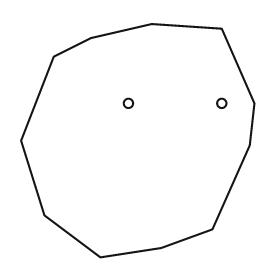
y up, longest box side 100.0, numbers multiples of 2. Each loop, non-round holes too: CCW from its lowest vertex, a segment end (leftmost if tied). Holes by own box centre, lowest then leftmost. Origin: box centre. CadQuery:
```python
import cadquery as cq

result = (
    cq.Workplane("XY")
    .moveTo(-16.0, -50.0)
    .lineTo(10.0, -46.0)
    .lineTo(32.0, -38.0)
    .lineTo(48.0, -2.0)
    .lineTo(50.0, 16.0)
    .lineTo(36.0, 48.0)
    .lineTo(6.0, 50.0)
    .lineTo(-20.0, 44.0)
    .lineTo(-36.0, 36.0)
    .lineTo(-50.0, 0.0)
    .lineTo(-40.0, -32.0)
    .close()
    .moveTo(-4.0, 16.0)
    .circle(2.0)
    .moveTo(36.0, 16.0)
    .circle(2.0)
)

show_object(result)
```